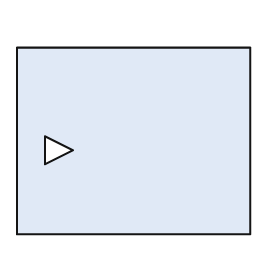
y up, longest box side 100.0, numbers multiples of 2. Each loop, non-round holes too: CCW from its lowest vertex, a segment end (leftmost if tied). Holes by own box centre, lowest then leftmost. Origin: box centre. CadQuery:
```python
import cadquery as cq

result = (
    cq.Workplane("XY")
    .moveTo(-50.0, -40.0)
    .lineTo(50.0, -40.0)
    .lineTo(50.0, 40.0)
    .lineTo(-50.0, 40.0)
    .close()
    .moveTo(-38.0, -10.0)
    .lineTo(-26.0, -4.0)
    .lineTo(-38.0, 2.0)
    .close()
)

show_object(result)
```